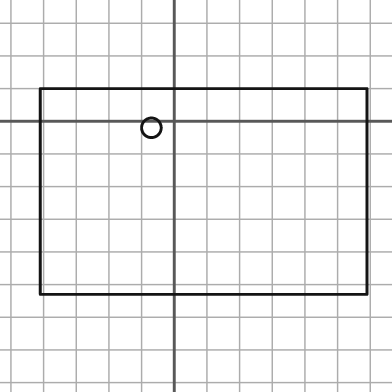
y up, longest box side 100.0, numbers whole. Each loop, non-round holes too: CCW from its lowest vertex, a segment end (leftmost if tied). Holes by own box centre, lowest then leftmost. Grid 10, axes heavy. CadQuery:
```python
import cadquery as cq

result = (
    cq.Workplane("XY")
    .moveTo(-41.0, -53.0)
    .lineTo(59.0, -53.0)
    .lineTo(59.0, 10.0)
    .lineTo(-41.0, 10.0)
    .close()
    .moveTo(-7.0, -2.0)
    .circle(3.0)
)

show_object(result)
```